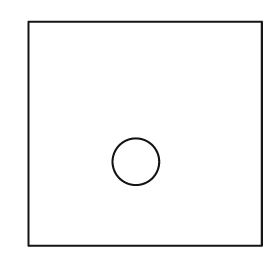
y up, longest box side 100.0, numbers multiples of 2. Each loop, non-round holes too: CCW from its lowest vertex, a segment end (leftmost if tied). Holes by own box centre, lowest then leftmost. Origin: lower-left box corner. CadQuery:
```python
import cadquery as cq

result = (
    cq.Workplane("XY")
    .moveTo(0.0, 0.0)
    .lineTo(100.0, 0.0)
    .lineTo(100.0, 96.0)
    .lineTo(0.0, 96.0)
    .close()
    .moveTo(46.0, 36.0)
    .circle(10.0)
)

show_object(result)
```